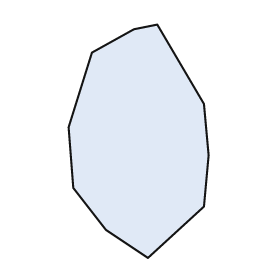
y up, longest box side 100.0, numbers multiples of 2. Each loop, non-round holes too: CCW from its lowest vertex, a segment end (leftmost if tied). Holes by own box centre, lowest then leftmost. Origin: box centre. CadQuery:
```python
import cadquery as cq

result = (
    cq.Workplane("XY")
    .moveTo(4.0, -50.0)
    .lineTo(28.0, -28.0)
    .lineTo(30.0, -6.0)
    .lineTo(28.0, 16.0)
    .lineTo(8.0, 50.0)
    .lineTo(-2.0, 48.0)
    .lineTo(-20.0, 38.0)
    .lineTo(-30.0, 6.0)
    .lineTo(-28.0, -20.0)
    .lineTo(-14.0, -38.0)
    .close()
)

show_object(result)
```